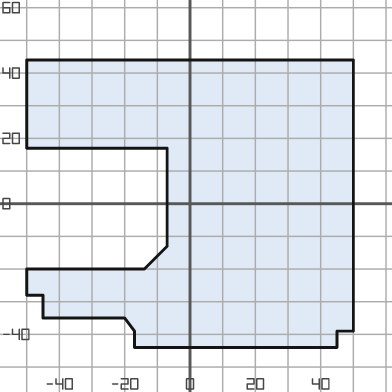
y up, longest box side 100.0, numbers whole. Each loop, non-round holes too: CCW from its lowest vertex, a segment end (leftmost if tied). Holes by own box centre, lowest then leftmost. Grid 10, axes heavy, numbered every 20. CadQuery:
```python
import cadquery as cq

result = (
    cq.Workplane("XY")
    .moveTo(-17.0, -44.0)
    .lineTo(45.0, -44.0)
    .lineTo(45.0, -39.0)
    .lineTo(50.0, -39.0)
    .lineTo(50.0, 44.0)
    .lineTo(-50.0, 44.0)
    .lineTo(-50.0, 17.0)
    .lineTo(-7.0, 17.0)
    .lineTo(-7.0, -13.0)
    .lineTo(-14.0, -20.0)
    .lineTo(-50.0, -20.0)
    .lineTo(-50.0, -28.0)
    .lineTo(-45.0, -28.0)
    .lineTo(-45.0, -35.0)
    .lineTo(-20.0, -35.0)
    .lineTo(-17.0, -39.0)
    .close()
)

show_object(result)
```